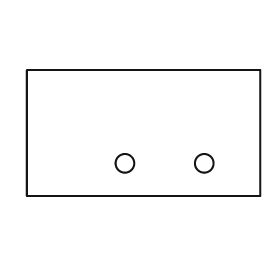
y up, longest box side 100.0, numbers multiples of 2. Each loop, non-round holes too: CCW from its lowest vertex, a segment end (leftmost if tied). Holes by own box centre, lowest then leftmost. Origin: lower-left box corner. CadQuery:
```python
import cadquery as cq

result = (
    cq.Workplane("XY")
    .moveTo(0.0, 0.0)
    .lineTo(100.0, 0.0)
    .lineTo(100.0, 54.0)
    .lineTo(0.0, 54.0)
    .close()
    .moveTo(42.0, 14.0)
    .circle(4.0)
    .moveTo(76.0, 14.0)
    .circle(4.0)
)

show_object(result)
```